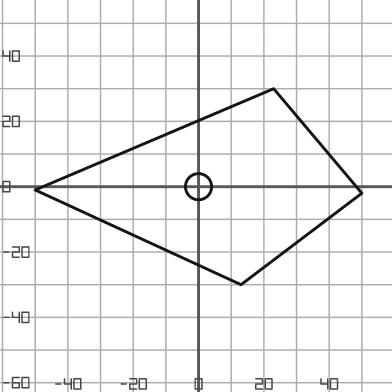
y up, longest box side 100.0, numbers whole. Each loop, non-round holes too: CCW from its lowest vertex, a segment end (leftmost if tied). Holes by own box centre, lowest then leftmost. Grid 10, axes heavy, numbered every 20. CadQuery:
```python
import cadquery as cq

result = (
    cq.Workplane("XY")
    .moveTo(13.0, -30.0)
    .lineTo(50.0, -2.0)
    .lineTo(23.0, 30.0)
    .lineTo(-50.0, -1.0)
    .close()
    .moveTo(0.0, 0.0)
    .circle(4.0)
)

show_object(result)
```